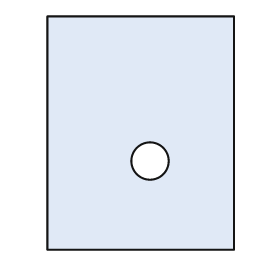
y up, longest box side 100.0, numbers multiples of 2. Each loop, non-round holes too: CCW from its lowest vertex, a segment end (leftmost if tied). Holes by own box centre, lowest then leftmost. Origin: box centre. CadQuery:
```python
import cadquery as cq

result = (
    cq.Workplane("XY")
    .moveTo(-40.0, -50.0)
    .lineTo(40.0, -50.0)
    .lineTo(40.0, 50.0)
    .lineTo(-40.0, 50.0)
    .close()
    .moveTo(4.0, -12.0)
    .circle(8.0)
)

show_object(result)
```